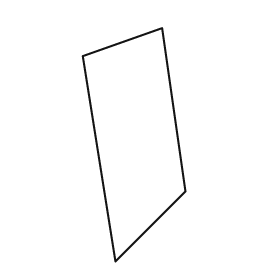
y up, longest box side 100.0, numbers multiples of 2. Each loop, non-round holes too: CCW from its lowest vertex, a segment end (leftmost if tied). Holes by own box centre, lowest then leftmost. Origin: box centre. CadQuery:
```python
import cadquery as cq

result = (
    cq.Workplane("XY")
    .moveTo(-8.0, -50.0)
    .lineTo(22.0, -20.0)
    .lineTo(12.0, 50.0)
    .lineTo(-22.0, 38.0)
    .close()
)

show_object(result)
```